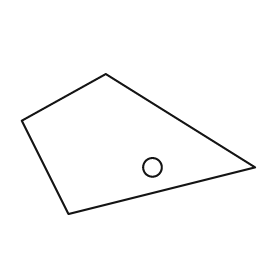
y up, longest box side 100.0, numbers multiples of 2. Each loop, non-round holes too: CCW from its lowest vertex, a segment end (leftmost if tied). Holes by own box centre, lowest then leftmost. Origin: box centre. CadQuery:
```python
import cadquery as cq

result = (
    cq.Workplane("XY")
    .moveTo(-30.0, -30.0)
    .lineTo(50.0, -10.0)
    .lineTo(-14.0, 30.0)
    .lineTo(-50.0, 10.0)
    .close()
    .moveTo(6.0, -10.0)
    .circle(4.0)
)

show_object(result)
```